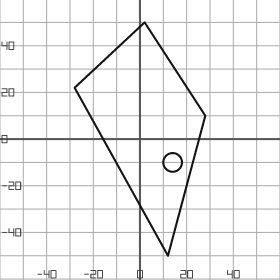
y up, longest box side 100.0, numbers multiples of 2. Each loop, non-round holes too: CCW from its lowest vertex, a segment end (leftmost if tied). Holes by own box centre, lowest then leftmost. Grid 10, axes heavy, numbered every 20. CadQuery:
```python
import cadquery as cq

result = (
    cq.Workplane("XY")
    .moveTo(12.0, -50.0)
    .lineTo(28.0, 10.0)
    .lineTo(2.0, 50.0)
    .lineTo(-28.0, 22.0)
    .close()
    .moveTo(14.0, -10.0)
    .circle(4.0)
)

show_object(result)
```